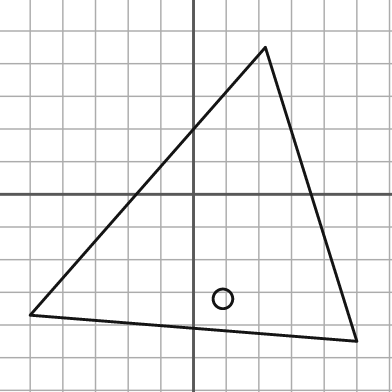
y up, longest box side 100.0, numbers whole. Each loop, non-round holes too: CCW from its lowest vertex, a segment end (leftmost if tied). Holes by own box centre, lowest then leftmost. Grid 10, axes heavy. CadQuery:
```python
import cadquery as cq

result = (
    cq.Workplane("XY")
    .moveTo(50.0, -45.0)
    .lineTo(22.0, 45.0)
    .lineTo(-50.0, -37.0)
    .close()
    .moveTo(9.0, -32.0)
    .circle(3.0)
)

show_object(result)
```